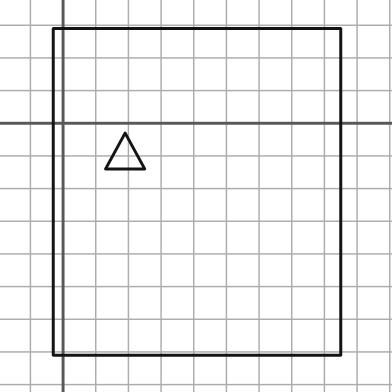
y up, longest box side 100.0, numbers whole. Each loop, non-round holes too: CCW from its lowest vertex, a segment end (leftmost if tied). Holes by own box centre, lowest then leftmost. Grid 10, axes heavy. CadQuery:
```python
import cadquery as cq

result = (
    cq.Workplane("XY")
    .moveTo(-3.0, -71.0)
    .lineTo(85.0, -71.0)
    .lineTo(85.0, 29.0)
    .lineTo(-3.0, 29.0)
    .close()
    .moveTo(13.0, -14.0)
    .lineTo(25.0, -14.0)
    .lineTo(19.0, -3.0)
    .close()
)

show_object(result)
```